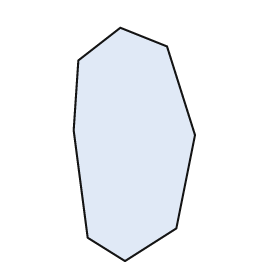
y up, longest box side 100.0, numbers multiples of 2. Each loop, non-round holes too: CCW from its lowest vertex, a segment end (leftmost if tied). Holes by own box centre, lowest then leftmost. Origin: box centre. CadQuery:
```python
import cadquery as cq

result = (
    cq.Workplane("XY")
    .moveTo(-4.0, -50.0)
    .lineTo(18.0, -36.0)
    .lineTo(26.0, 4.0)
    .lineTo(14.0, 42.0)
    .lineTo(-6.0, 50.0)
    .lineTo(-24.0, 36.0)
    .lineTo(-26.0, 6.0)
    .lineTo(-20.0, -40.0)
    .close()
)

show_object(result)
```